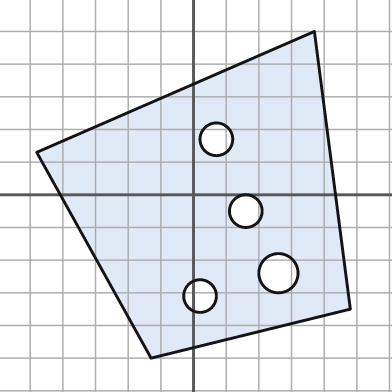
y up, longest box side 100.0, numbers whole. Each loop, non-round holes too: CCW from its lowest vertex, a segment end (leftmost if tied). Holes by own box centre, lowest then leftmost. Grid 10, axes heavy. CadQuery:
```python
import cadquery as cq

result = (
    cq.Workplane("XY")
    .moveTo(-13.0, -50.0)
    .lineTo(48.0, -35.0)
    .lineTo(37.0, 50.0)
    .lineTo(-48.0, 13.0)
    .close()
    .moveTo(2.0, -31.0)
    .circle(5.0)
    .moveTo(26.0, -24.0)
    .circle(6.0)
    .moveTo(16.0, -5.0)
    .circle(5.0)
    .moveTo(7.0, 17.0)
    .circle(5.0)
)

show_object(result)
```